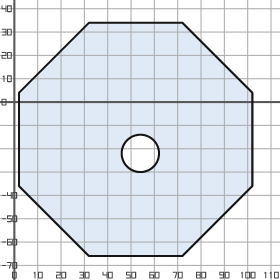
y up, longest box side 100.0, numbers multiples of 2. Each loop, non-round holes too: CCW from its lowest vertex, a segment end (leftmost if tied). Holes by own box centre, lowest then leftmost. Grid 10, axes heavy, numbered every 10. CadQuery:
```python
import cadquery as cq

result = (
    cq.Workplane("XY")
    .moveTo(32.0, -66.0)
    .lineTo(72.0, -66.0)
    .lineTo(102.0, -36.0)
    .lineTo(102.0, 4.0)
    .lineTo(72.0, 34.0)
    .lineTo(32.0, 34.0)
    .lineTo(2.0, 4.0)
    .lineTo(2.0, -36.0)
    .close()
    .moveTo(54.0, -22.0)
    .circle(8.0)
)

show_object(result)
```